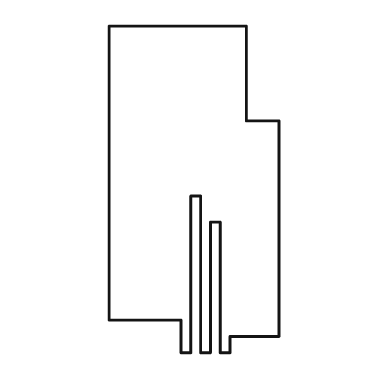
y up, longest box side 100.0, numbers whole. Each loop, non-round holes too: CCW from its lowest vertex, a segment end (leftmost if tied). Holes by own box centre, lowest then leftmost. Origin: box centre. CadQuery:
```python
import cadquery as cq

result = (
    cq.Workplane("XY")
    .moveTo(-4.0, -50.0)
    .lineTo(-1.0, -50.0)
    .lineTo(-1.0, -2.0)
    .lineTo(2.0, -2.0)
    .lineTo(2.0, -50.0)
    .lineTo(5.0, -50.0)
    .lineTo(5.0, -10.0)
    .lineTo(8.0, -10.0)
    .lineTo(8.0, -50.0)
    .lineTo(11.0, -50.0)
    .lineTo(11.0, -45.0)
    .lineTo(26.0, -45.0)
    .lineTo(26.0, 21.0)
    .lineTo(16.0, 21.0)
    .lineTo(16.0, 50.0)
    .lineTo(-26.0, 50.0)
    .lineTo(-26.0, -40.0)
    .lineTo(-4.0, -40.0)
    .close()
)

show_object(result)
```